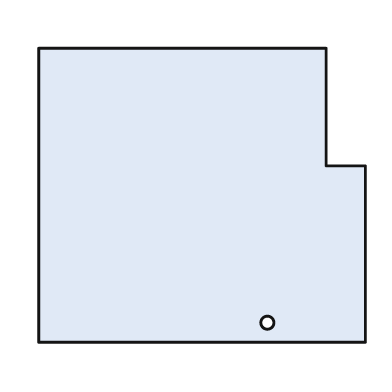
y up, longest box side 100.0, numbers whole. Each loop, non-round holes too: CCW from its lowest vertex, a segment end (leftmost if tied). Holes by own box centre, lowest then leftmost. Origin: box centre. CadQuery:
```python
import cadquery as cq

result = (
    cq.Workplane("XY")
    .moveTo(-50.0, -45.0)
    .lineTo(50.0, -45.0)
    .lineTo(50.0, 9.0)
    .lineTo(38.0, 9.0)
    .lineTo(38.0, 45.0)
    .lineTo(-50.0, 45.0)
    .close()
    .moveTo(20.0, -39.0)
    .circle(2.0)
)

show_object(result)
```